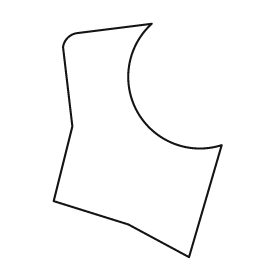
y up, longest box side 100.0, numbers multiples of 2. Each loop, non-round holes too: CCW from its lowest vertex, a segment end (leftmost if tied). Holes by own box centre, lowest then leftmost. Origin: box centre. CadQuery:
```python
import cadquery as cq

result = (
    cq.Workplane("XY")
    .moveTo(22.0, -50.0)
    .lineTo(36.0, -2.0)
    .threePointArc((0.0, 12.0), (6.0, 50.0))
    .lineTo(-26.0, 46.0)
    .threePointArc((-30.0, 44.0), (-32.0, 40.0))
    .lineTo(-28.0, 6.0)
    .lineTo(-36.0, -26.0)
    .lineTo(-4.0, -36.0)
    .close()
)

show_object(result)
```